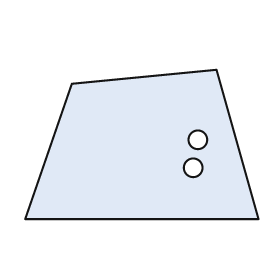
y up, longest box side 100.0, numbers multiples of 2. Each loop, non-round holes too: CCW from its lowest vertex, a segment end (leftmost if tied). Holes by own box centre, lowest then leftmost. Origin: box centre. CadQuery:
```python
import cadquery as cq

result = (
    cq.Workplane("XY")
    .moveTo(-50.0, -32.0)
    .lineTo(50.0, -32.0)
    .lineTo(32.0, 32.0)
    .lineTo(-30.0, 26.0)
    .close()
    .moveTo(22.0, -10.0)
    .circle(4.0)
    .moveTo(24.0, 2.0)
    .circle(4.0)
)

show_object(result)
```